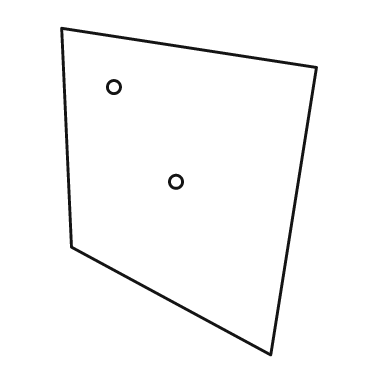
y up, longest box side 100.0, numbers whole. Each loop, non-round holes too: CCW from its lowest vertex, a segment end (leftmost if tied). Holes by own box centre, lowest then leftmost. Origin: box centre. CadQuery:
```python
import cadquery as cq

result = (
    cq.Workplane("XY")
    .moveTo(25.0, -50.0)
    .lineTo(39.0, 38.0)
    .lineTo(-39.0, 50.0)
    .lineTo(-36.0, -17.0)
    .close()
    .moveTo(-4.0, 3.0)
    .circle(2.0)
    .moveTo(-23.0, 32.0)
    .circle(2.0)
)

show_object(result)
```